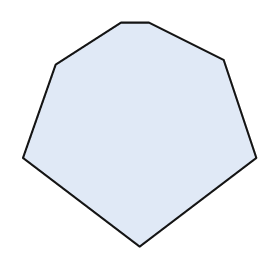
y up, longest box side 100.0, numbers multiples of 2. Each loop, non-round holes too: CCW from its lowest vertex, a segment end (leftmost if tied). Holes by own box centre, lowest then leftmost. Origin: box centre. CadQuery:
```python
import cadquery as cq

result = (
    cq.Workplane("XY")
    .moveTo(0.0, -48.0)
    .lineTo(50.0, -10.0)
    .lineTo(36.0, 32.0)
    .lineTo(4.0, 48.0)
    .lineTo(-8.0, 48.0)
    .lineTo(-36.0, 30.0)
    .lineTo(-50.0, -10.0)
    .close()
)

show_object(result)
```